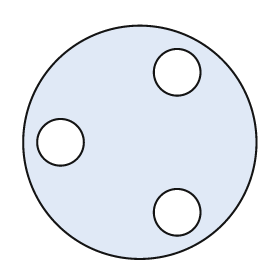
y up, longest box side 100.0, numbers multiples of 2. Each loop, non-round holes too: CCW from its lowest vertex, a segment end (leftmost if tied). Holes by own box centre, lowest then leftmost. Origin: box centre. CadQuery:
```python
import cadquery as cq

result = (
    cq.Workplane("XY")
    .moveTo(0.0, 0.0)
    .circle(50.0)
    .moveTo(16.0, -30.0)
    .circle(10.0)
    .moveTo(-34.0, 0.0)
    .circle(10.0)
    .moveTo(16.0, 30.0)
    .circle(10.0)
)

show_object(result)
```